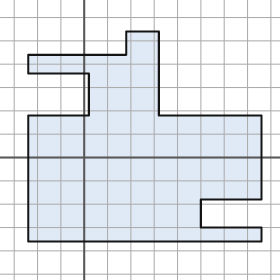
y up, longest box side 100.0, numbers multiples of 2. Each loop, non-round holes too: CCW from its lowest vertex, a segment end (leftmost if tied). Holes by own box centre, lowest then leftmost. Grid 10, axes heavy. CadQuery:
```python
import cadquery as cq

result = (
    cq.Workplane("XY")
    .moveTo(-24.0, -36.0)
    .lineTo(76.0, -36.0)
    .lineTo(76.0, -30.0)
    .lineTo(50.0, -30.0)
    .lineTo(50.0, -18.0)
    .lineTo(76.0, -18.0)
    .lineTo(76.0, 18.0)
    .lineTo(32.0, 18.0)
    .lineTo(32.0, 54.0)
    .lineTo(18.0, 54.0)
    .lineTo(18.0, 44.0)
    .lineTo(-24.0, 44.0)
    .lineTo(-24.0, 36.0)
    .lineTo(2.0, 36.0)
    .lineTo(2.0, 18.0)
    .lineTo(-24.0, 18.0)
    .close()
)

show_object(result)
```